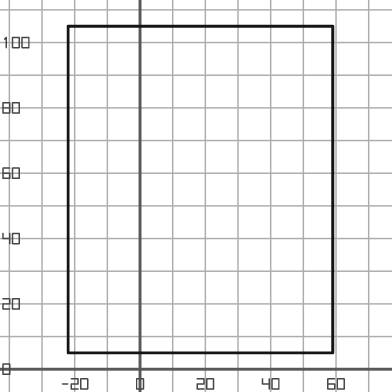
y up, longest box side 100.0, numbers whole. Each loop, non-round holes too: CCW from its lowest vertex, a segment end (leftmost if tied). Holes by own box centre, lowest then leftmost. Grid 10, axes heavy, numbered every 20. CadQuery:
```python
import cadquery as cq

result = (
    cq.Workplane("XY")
    .moveTo(-22.0, 5.0)
    .lineTo(59.0, 5.0)
    .lineTo(59.0, 105.0)
    .lineTo(-22.0, 105.0)
    .close()
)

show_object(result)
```